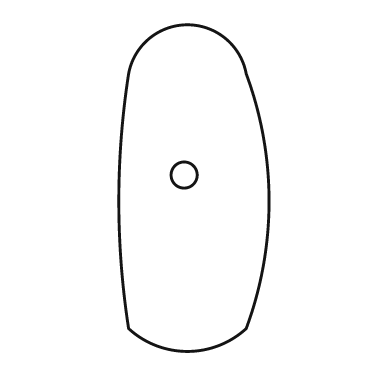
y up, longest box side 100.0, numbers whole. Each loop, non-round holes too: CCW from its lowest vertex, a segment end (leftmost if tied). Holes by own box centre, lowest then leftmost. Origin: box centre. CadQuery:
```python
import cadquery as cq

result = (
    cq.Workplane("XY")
    .moveTo(-20.0, -43.0)
    .threePointArc((-2.0, -50.0), (16.0, -43.0))
    .threePointArc((23.0, -4.0), (16.0, 35.0))
    .threePointArc((-2.0, 50.0), (-20.0, 35.0))
    .threePointArc((-23.0, -4.0), (-20.0, -43.0))
    .close()
    .moveTo(-3.0, 4.0)
    .circle(4.0)
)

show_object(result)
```